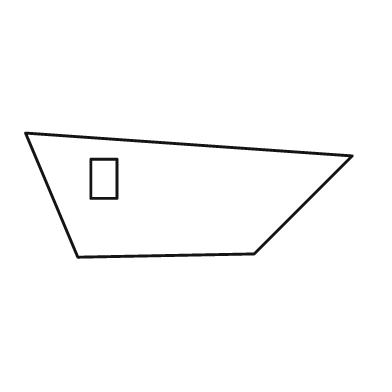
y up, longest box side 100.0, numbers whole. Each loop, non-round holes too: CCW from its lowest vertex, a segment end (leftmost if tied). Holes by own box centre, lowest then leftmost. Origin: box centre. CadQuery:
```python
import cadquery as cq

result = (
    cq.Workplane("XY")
    .moveTo(-34.0, -19.0)
    .lineTo(20.0, -18.0)
    .lineTo(50.0, 12.0)
    .lineTo(-50.0, 19.0)
    .close()
    .moveTo(-30.0, -1.0)
    .lineTo(-22.0, -1.0)
    .lineTo(-22.0, 11.0)
    .lineTo(-30.0, 11.0)
    .close()
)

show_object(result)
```